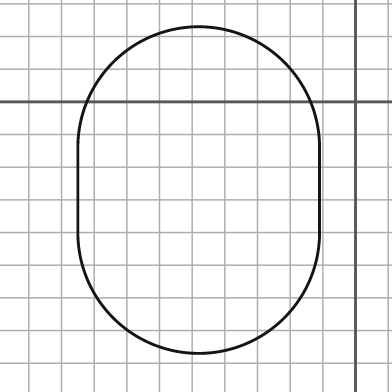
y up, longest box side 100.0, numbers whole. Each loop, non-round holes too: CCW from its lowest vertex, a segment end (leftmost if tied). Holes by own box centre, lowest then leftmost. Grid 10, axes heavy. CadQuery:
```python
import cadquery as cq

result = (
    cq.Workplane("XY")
    .moveTo(-85.0, -40.0)
    .threePointArc((-48.0, -77.0), (-11.0, -40.0))
    .lineTo(-11.0, -14.0)
    .threePointArc((-48.0, 23.0), (-85.0, -14.0))
    .close()
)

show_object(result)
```